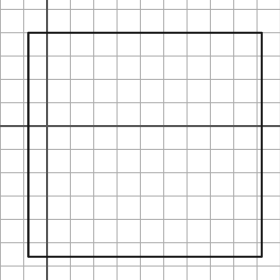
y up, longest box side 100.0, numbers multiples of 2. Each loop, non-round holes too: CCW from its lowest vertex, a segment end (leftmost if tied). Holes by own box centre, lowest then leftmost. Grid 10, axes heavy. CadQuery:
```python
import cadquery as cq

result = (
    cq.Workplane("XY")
    .moveTo(-8.0, -56.0)
    .lineTo(92.0, -56.0)
    .lineTo(92.0, 40.0)
    .lineTo(-8.0, 40.0)
    .close()
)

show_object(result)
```